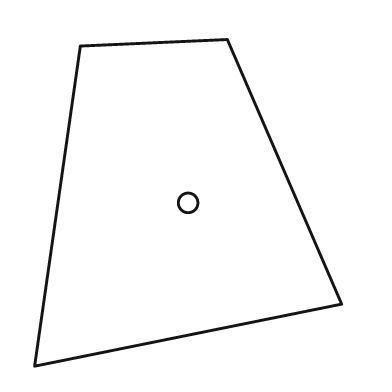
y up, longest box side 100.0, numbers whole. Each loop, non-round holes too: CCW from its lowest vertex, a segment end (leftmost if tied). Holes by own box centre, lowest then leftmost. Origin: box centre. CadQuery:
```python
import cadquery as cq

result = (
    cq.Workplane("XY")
    .moveTo(-47.0, -50.0)
    .lineTo(47.0, -31.0)
    .lineTo(12.0, 50.0)
    .lineTo(-33.0, 48.0)
    .close()
    .moveTo(0.0, 0.0)
    .circle(3.0)
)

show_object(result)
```